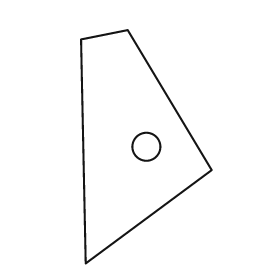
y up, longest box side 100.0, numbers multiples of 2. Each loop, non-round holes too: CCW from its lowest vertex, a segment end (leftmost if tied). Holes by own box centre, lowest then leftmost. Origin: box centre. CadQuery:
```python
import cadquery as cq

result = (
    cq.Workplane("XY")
    .moveTo(-26.0, -50.0)
    .lineTo(28.0, -10.0)
    .lineTo(-8.0, 50.0)
    .lineTo(-28.0, 46.0)
    .close()
    .moveTo(0.0, 0.0)
    .circle(6.0)
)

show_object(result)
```